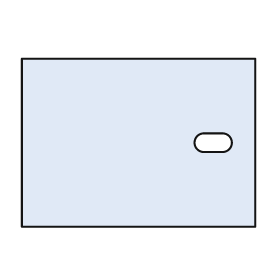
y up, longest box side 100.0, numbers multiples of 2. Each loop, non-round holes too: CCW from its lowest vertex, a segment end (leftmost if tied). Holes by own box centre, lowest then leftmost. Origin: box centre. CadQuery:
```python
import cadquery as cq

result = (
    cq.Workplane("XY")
    .moveTo(-50.0, -36.0)
    .lineTo(50.0, -36.0)
    .lineTo(50.0, 36.0)
    .lineTo(-50.0, 36.0)
    .close()
    .moveTo(28.0, -4.0)
    .lineTo(36.0, -4.0)
    .threePointArc((40.0, 0.0), (36.0, 4.0))
    .lineTo(28.0, 4.0)
    .threePointArc((24.0, 0.0), (28.0, -4.0))
    .close()
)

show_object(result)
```